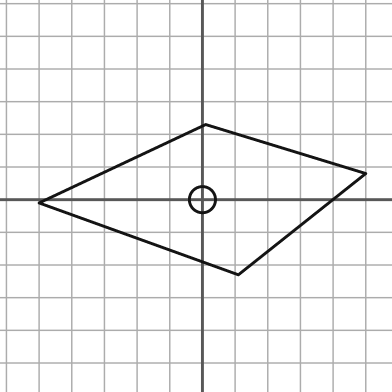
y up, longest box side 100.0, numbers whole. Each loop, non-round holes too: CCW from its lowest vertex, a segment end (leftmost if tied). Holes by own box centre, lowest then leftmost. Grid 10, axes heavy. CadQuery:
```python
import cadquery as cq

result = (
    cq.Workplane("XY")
    .moveTo(11.0, -23.0)
    .lineTo(50.0, 8.0)
    .lineTo(1.0, 23.0)
    .lineTo(-50.0, -1.0)
    .close()
    .moveTo(0.0, 0.0)
    .circle(4.0)
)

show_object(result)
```